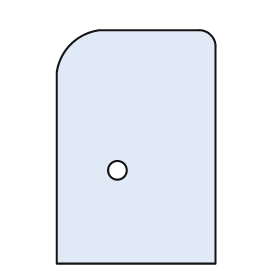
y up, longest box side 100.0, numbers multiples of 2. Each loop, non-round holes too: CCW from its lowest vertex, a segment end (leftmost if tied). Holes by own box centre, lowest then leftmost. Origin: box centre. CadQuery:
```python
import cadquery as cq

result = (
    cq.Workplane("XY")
    .moveTo(-34.0, -50.0)
    .lineTo(34.0, -50.0)
    .lineTo(34.0, 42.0)
    .threePointArc((32.0, 48.0), (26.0, 50.0))
    .lineTo(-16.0, 50.0)
    .threePointArc((-28.0, 44.0), (-34.0, 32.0))
    .close()
    .moveTo(-8.0, -10.0)
    .circle(4.0)
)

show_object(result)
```